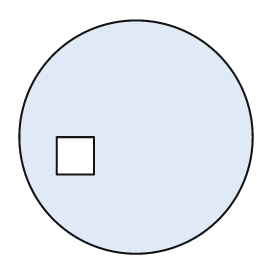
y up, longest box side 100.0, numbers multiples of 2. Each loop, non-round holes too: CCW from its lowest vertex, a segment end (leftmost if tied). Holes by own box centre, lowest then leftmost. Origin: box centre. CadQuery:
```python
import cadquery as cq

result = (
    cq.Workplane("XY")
    .moveTo(0.0, 0.0)
    .circle(50.0)
    .moveTo(-34.0, -16.0)
    .lineTo(-18.0, -16.0)
    .lineTo(-18.0, 0.0)
    .lineTo(-34.0, 0.0)
    .close()
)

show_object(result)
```